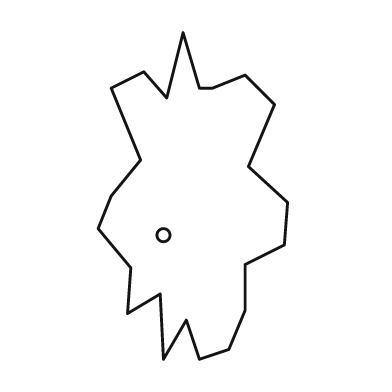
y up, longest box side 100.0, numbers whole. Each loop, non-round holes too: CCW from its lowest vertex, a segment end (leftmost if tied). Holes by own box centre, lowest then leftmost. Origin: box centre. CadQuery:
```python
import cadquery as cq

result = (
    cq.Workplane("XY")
    .moveTo(-9.0, -50.0)
    .lineTo(-2.0, -38.0)
    .lineTo(2.0, -50.0)
    .lineTo(11.0, -47.0)
    .lineTo(16.0, -35.0)
    .lineTo(16.0, -21.0)
    .lineTo(28.0, -15.0)
    .lineTo(29.0, -2.0)
    .lineTo(17.0, 9.0)
    .lineTo(25.0, 28.0)
    .lineTo(16.0, 37.0)
    .lineTo(6.0, 33.0)
    .lineTo(2.0, 33.0)
    .lineTo(-3.0, 50.0)
    .lineTo(-8.0, 30.0)
    .lineTo(-15.0, 38.0)
    .lineTo(-25.0, 33.0)
    .lineTo(-16.0, 11.0)
    .lineTo(-25.0, 0.0)
    .lineTo(-29.0, -10.0)
    .lineTo(-19.0, -22.0)
    .lineTo(-20.0, -36.0)
    .lineTo(-10.0, -30.0)
    .close()
    .moveTo(-9.0, -12.0)
    .circle(2.0)
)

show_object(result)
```